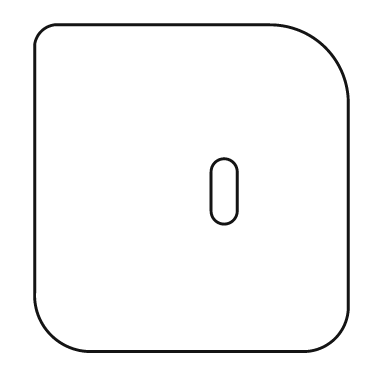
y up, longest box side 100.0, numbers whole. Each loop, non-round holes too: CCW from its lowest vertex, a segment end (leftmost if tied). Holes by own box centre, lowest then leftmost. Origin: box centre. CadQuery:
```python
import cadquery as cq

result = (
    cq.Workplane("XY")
    .moveTo(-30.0, -50.0)
    .lineTo(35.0, -50.0)
    .threePointArc((44.0, -46.0), (48.0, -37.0))
    .lineTo(48.0, 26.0)
    .threePointArc((41.0, 43.0), (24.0, 50.0))
    .lineTo(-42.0, 50.0)
    .threePointArc((-46.0, 48.0), (-48.0, 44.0))
    .lineTo(-48.0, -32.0)
    .threePointArc((-43.0, -45.0), (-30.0, -50.0))
    .close()
    .moveTo(6.0, -7.0)
    .threePointArc((10.0, -11.0), (14.0, -7.0))
    .lineTo(14.0, 5.0)
    .threePointArc((10.0, 9.0), (6.0, 5.0))
    .close()
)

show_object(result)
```